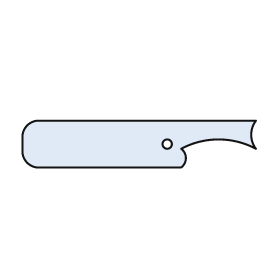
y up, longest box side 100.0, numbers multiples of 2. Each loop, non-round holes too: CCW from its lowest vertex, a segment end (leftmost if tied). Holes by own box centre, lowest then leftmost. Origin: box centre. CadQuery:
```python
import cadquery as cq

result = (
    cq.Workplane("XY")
    .moveTo(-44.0, -10.0)
    .lineTo(18.0, -10.0)
    .threePointArc((20.0, -6.0), (18.0, -2.0))
    .threePointArc((34.0, 2.0), (50.0, -2.0))
    .threePointArc((48.0, 4.0), (50.0, 10.0))
    .lineTo(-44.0, 10.0)
    .threePointArc((-48.0, 8.0), (-50.0, 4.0))
    .lineTo(-50.0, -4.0)
    .threePointArc((-48.0, -8.0), (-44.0, -10.0))
    .close()
    .moveTo(12.0, 0.0)
    .circle(2.0)
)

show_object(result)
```